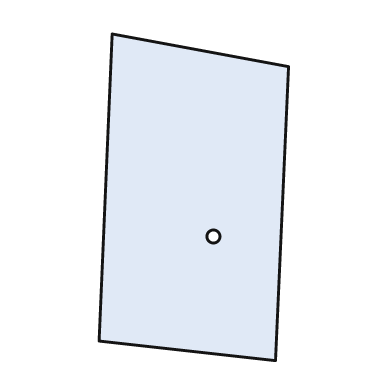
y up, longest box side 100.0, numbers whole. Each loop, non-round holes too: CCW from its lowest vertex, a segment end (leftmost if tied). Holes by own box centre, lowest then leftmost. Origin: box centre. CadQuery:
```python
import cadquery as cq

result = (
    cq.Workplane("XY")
    .moveTo(25.0, -50.0)
    .lineTo(29.0, 40.0)
    .lineTo(-25.0, 50.0)
    .lineTo(-29.0, -44.0)
    .close()
    .moveTo(6.0, -12.0)
    .circle(2.0)
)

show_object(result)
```